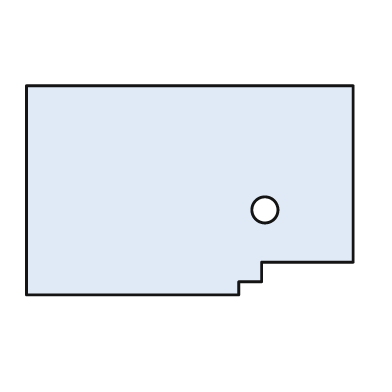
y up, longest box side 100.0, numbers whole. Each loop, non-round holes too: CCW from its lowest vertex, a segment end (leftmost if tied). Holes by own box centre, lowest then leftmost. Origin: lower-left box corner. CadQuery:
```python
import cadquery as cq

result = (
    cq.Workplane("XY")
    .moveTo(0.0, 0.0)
    .lineTo(65.0, 0.0)
    .lineTo(65.0, 4.0)
    .lineTo(72.0, 4.0)
    .lineTo(72.0, 10.0)
    .lineTo(100.0, 10.0)
    .lineTo(100.0, 64.0)
    .lineTo(0.0, 64.0)
    .close()
    .moveTo(73.0, 26.0)
    .circle(4.0)
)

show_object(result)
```